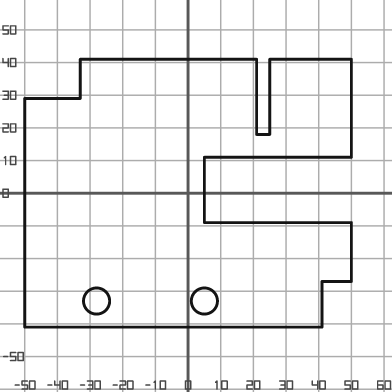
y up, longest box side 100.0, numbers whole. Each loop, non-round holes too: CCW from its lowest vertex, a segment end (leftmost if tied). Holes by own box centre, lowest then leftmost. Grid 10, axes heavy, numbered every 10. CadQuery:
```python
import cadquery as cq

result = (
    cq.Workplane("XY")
    .moveTo(-50.0, -41.0)
    .lineTo(41.0, -41.0)
    .lineTo(41.0, -27.0)
    .lineTo(50.0, -27.0)
    .lineTo(50.0, -9.0)
    .lineTo(5.0, -9.0)
    .lineTo(5.0, 11.0)
    .lineTo(50.0, 11.0)
    .lineTo(50.0, 41.0)
    .lineTo(25.0, 41.0)
    .lineTo(25.0, 18.0)
    .lineTo(21.0, 18.0)
    .lineTo(21.0, 41.0)
    .lineTo(-33.0, 41.0)
    .lineTo(-33.0, 29.0)
    .lineTo(-50.0, 29.0)
    .close()
    .moveTo(-28.0, -33.0)
    .circle(4.0)
    .moveTo(5.0, -33.0)
    .circle(4.0)
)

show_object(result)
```